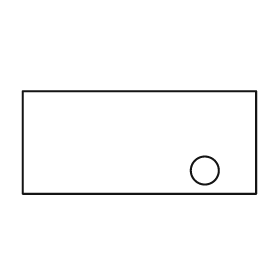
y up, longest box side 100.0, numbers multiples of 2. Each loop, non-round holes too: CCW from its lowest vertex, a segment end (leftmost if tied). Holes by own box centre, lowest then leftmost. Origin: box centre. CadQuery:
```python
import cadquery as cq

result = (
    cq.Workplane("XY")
    .moveTo(-50.0, -22.0)
    .lineTo(50.0, -22.0)
    .lineTo(50.0, 22.0)
    .lineTo(-50.0, 22.0)
    .close()
    .moveTo(28.0, -12.0)
    .circle(6.0)
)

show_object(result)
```